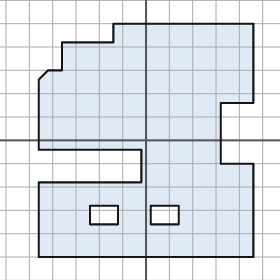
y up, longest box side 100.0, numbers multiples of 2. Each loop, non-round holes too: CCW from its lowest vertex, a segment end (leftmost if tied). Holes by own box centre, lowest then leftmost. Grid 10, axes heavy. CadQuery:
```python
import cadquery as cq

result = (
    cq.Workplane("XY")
    .moveTo(-46.0, -50.0)
    .lineTo(46.0, -50.0)
    .lineTo(46.0, -10.0)
    .lineTo(32.0, -10.0)
    .lineTo(32.0, 16.0)
    .lineTo(46.0, 16.0)
    .lineTo(46.0, 50.0)
    .lineTo(-14.0, 50.0)
    .lineTo(-14.0, 42.0)
    .lineTo(-36.0, 42.0)
    .lineTo(-36.0, 30.0)
    .lineTo(-42.0, 30.0)
    .lineTo(-46.0, 26.0)
    .lineTo(-46.0, -4.0)
    .lineTo(-2.0, -4.0)
    .lineTo(-2.0, -18.0)
    .lineTo(-46.0, -18.0)
    .close()
    .moveTo(-24.0, -36.0)
    .lineTo(-12.0, -36.0)
    .lineTo(-12.0, -28.0)
    .lineTo(-24.0, -28.0)
    .close()
    .moveTo(2.0, -36.0)
    .lineTo(14.0, -36.0)
    .lineTo(14.0, -28.0)
    .lineTo(2.0, -28.0)
    .close()
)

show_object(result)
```